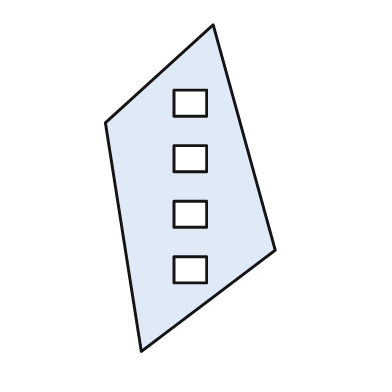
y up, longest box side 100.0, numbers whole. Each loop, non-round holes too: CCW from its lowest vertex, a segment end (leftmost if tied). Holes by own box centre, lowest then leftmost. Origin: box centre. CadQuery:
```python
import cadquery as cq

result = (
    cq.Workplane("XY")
    .moveTo(-15.0, -50.0)
    .lineTo(26.0, -19.0)
    .lineTo(7.0, 50.0)
    .lineTo(-26.0, 20.0)
    .close()
    .moveTo(-5.0, -29.0)
    .lineTo(5.0, -29.0)
    .lineTo(5.0, -21.0)
    .lineTo(-5.0, -21.0)
    .close()
    .moveTo(-5.0, -12.0)
    .lineTo(5.0, -12.0)
    .lineTo(5.0, -4.0)
    .lineTo(-5.0, -4.0)
    .close()
    .moveTo(-5.0, 5.0)
    .lineTo(5.0, 5.0)
    .lineTo(5.0, 13.0)
    .lineTo(-5.0, 13.0)
    .close()
    .moveTo(-5.0, 22.0)
    .lineTo(5.0, 22.0)
    .lineTo(5.0, 30.0)
    .lineTo(-5.0, 30.0)
    .close()
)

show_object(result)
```